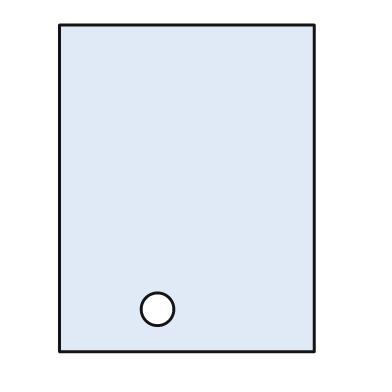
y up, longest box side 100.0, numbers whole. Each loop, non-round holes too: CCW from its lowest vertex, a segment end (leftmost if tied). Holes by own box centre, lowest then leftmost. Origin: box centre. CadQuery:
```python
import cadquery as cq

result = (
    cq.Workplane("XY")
    .moveTo(-39.0, -50.0)
    .lineTo(39.0, -50.0)
    .lineTo(39.0, 50.0)
    .lineTo(-39.0, 50.0)
    .close()
    .moveTo(-9.0, -37.0)
    .circle(5.0)
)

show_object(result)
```